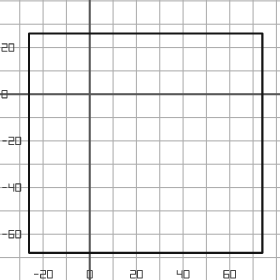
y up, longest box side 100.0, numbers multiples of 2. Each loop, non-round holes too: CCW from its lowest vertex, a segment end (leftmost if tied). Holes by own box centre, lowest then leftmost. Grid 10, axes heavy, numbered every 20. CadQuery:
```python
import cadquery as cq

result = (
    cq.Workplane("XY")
    .moveTo(-26.0, -68.0)
    .lineTo(74.0, -68.0)
    .lineTo(74.0, 26.0)
    .lineTo(-26.0, 26.0)
    .close()
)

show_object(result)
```